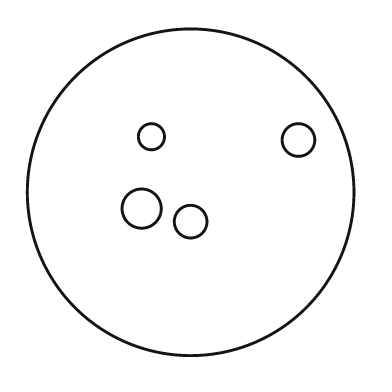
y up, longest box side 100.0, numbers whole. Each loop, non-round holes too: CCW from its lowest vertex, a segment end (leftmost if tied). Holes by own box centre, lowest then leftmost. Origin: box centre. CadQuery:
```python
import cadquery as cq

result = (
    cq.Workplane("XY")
    .moveTo(0.0, 0.0)
    .circle(50.0)
    .moveTo(0.0, -9.0)
    .circle(5.0)
    .moveTo(-15.0, -5.0)
    .circle(6.0)
    .moveTo(33.0, 16.0)
    .circle(5.0)
    .moveTo(-12.0, 17.0)
    .circle(4.0)
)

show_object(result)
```